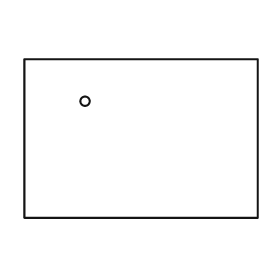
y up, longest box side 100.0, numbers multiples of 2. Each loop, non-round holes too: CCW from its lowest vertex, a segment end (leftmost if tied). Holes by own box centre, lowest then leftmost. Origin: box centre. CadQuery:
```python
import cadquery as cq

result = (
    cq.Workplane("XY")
    .moveTo(-50.0, -34.0)
    .lineTo(50.0, -34.0)
    .lineTo(50.0, 34.0)
    .lineTo(-50.0, 34.0)
    .close()
    .moveTo(-24.0, 16.0)
    .circle(2.0)
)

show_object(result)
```